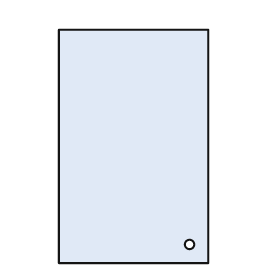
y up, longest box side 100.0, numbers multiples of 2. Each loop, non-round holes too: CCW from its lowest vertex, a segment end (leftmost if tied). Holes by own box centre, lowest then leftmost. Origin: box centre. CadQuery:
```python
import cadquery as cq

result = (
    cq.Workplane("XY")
    .moveTo(-32.0, -50.0)
    .lineTo(32.0, -50.0)
    .lineTo(32.0, 50.0)
    .lineTo(-32.0, 50.0)
    .close()
    .moveTo(24.0, -42.0)
    .circle(2.0)
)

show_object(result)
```